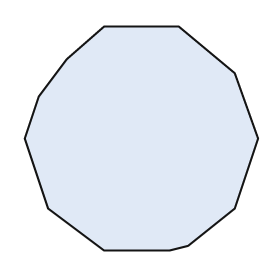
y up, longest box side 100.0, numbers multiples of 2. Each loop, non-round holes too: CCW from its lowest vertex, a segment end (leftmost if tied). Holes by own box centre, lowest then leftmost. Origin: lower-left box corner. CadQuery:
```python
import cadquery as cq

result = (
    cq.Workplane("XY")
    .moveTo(34.0, 0.0)
    .lineTo(62.0, 0.0)
    .lineTo(70.0, 2.0)
    .lineTo(90.0, 18.0)
    .lineTo(100.0, 48.0)
    .lineTo(90.0, 76.0)
    .lineTo(66.0, 96.0)
    .lineTo(34.0, 96.0)
    .lineTo(18.0, 82.0)
    .lineTo(6.0, 66.0)
    .lineTo(0.0, 48.0)
    .lineTo(10.0, 18.0)
    .close()
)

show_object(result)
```